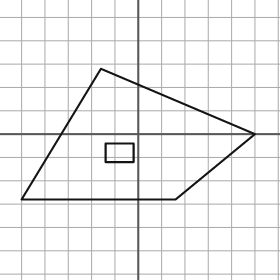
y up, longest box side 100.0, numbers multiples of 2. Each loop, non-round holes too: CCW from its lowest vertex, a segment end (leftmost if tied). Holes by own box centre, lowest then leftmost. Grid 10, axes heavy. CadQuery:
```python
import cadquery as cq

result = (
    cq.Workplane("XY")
    .moveTo(-50.0, -28.0)
    .lineTo(16.0, -28.0)
    .lineTo(50.0, 0.0)
    .lineTo(-16.0, 28.0)
    .close()
    .moveTo(-14.0, -12.0)
    .lineTo(-2.0, -12.0)
    .lineTo(-2.0, -4.0)
    .lineTo(-14.0, -4.0)
    .close()
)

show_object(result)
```